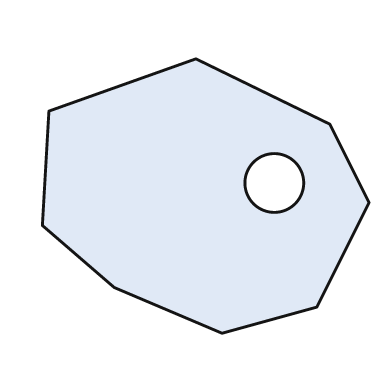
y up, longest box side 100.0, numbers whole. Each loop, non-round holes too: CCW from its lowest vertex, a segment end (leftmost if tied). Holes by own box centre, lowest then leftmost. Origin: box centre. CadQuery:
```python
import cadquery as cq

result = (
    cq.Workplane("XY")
    .moveTo(5.0, -42.0)
    .lineTo(34.0, -34.0)
    .lineTo(50.0, -2.0)
    .lineTo(38.0, 22.0)
    .lineTo(-3.0, 42.0)
    .lineTo(-48.0, 26.0)
    .lineTo(-50.0, -9.0)
    .lineTo(-28.0, -28.0)
    .close()
    .moveTo(21.0, 4.0)
    .circle(9.0)
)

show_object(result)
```